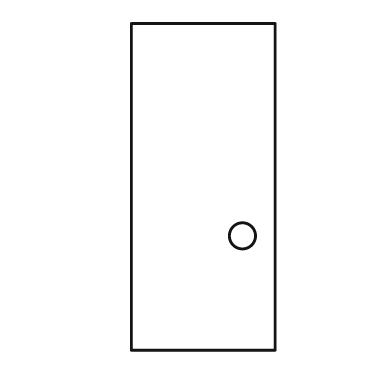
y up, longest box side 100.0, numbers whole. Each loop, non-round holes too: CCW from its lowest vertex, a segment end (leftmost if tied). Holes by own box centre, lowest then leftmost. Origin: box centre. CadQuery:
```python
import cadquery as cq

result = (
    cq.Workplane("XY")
    .moveTo(-22.0, -50.0)
    .lineTo(22.0, -50.0)
    .lineTo(22.0, 50.0)
    .lineTo(-22.0, 50.0)
    .close()
    .moveTo(12.0, -15.0)
    .circle(4.0)
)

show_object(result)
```